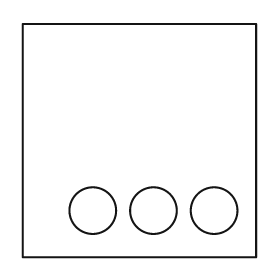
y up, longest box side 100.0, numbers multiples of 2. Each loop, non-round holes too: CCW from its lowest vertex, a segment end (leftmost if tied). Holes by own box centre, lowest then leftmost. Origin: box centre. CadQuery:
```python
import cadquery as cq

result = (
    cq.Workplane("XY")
    .moveTo(-50.0, -50.0)
    .lineTo(50.0, -50.0)
    .lineTo(50.0, 50.0)
    .lineTo(-50.0, 50.0)
    .close()
    .moveTo(-20.0, -30.0)
    .circle(10.0)
    .moveTo(6.0, -30.0)
    .circle(10.0)
    .moveTo(32.0, -30.0)
    .circle(10.0)
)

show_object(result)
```